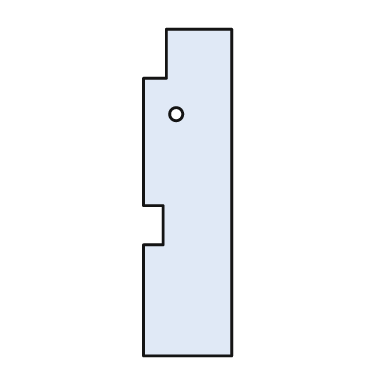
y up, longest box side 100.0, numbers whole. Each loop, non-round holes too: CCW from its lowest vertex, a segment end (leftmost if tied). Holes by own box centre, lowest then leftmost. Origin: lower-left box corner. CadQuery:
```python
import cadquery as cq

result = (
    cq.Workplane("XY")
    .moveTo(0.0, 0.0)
    .lineTo(27.0, 0.0)
    .lineTo(27.0, 100.0)
    .lineTo(7.0, 100.0)
    .lineTo(7.0, 85.0)
    .lineTo(0.0, 85.0)
    .lineTo(0.0, 46.0)
    .lineTo(6.0, 46.0)
    .lineTo(6.0, 34.0)
    .lineTo(0.0, 34.0)
    .close()
    .moveTo(10.0, 74.0)
    .circle(2.0)
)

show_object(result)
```